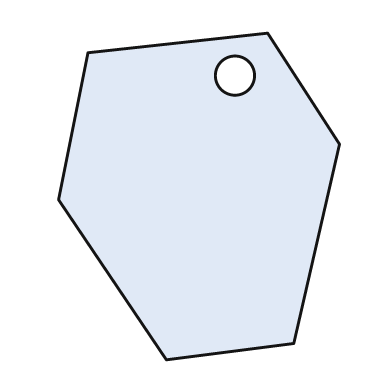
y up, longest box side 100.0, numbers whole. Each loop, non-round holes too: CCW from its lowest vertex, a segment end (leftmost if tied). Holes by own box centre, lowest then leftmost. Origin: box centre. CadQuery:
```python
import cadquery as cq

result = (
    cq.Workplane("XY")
    .moveTo(-10.0, -50.0)
    .lineTo(29.0, -45.0)
    .lineTo(43.0, 16.0)
    .lineTo(21.0, 50.0)
    .lineTo(-34.0, 44.0)
    .lineTo(-43.0, -1.0)
    .close()
    .moveTo(11.0, 37.0)
    .circle(6.0)
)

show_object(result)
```